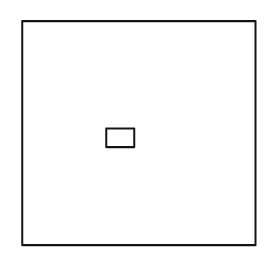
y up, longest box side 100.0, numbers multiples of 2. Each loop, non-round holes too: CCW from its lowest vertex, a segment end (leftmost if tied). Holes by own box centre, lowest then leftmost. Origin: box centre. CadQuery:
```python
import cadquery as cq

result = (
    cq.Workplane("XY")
    .moveTo(-50.0, -48.0)
    .lineTo(50.0, -48.0)
    .lineTo(50.0, 48.0)
    .lineTo(-50.0, 48.0)
    .close()
    .moveTo(-14.0, -6.0)
    .lineTo(-2.0, -6.0)
    .lineTo(-2.0, 2.0)
    .lineTo(-14.0, 2.0)
    .close()
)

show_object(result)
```